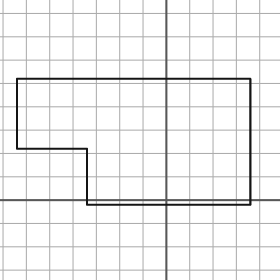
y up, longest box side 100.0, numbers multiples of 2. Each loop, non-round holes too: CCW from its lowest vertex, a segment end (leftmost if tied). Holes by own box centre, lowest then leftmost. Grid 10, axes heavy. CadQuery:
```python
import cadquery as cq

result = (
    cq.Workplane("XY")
    .moveTo(-34.0, -2.0)
    .lineTo(36.0, -2.0)
    .lineTo(36.0, 52.0)
    .lineTo(-64.0, 52.0)
    .lineTo(-64.0, 22.0)
    .lineTo(-34.0, 22.0)
    .close()
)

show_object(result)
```